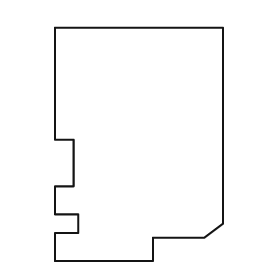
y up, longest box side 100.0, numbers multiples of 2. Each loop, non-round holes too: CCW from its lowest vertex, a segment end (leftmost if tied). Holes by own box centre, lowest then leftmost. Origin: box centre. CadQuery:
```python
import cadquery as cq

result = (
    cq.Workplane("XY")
    .moveTo(-36.0, -50.0)
    .lineTo(6.0, -50.0)
    .lineTo(6.0, -40.0)
    .lineTo(28.0, -40.0)
    .lineTo(36.0, -34.0)
    .lineTo(36.0, 50.0)
    .lineTo(-36.0, 50.0)
    .lineTo(-36.0, 2.0)
    .lineTo(-28.0, 2.0)
    .lineTo(-28.0, -18.0)
    .lineTo(-36.0, -18.0)
    .lineTo(-36.0, -30.0)
    .lineTo(-26.0, -30.0)
    .lineTo(-26.0, -38.0)
    .lineTo(-36.0, -38.0)
    .close()
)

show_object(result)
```